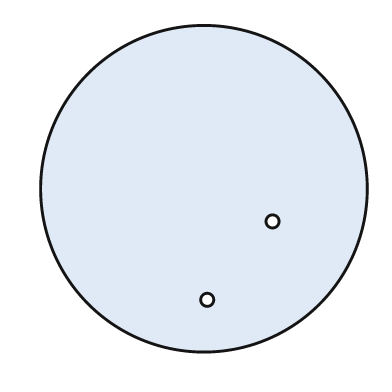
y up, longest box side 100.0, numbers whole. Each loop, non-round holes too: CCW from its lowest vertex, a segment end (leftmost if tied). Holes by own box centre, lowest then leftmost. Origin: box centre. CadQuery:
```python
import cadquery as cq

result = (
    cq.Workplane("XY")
    .moveTo(0.0, 0.0)
    .circle(50.0)
    .moveTo(1.0, -34.0)
    .circle(2.0)
    .moveTo(21.0, -10.0)
    .circle(2.0)
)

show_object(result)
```